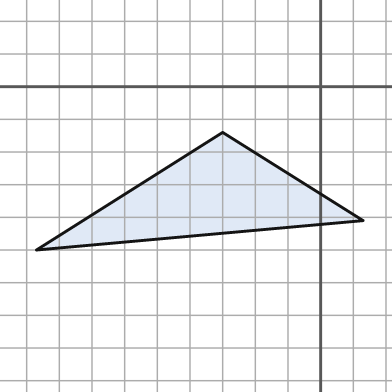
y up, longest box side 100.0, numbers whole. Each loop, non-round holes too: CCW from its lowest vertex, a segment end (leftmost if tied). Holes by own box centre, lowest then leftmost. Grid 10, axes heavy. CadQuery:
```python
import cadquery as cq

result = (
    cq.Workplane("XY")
    .moveTo(-87.0, -50.0)
    .lineTo(13.0, -41.0)
    .lineTo(-30.0, -14.0)
    .close()
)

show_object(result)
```